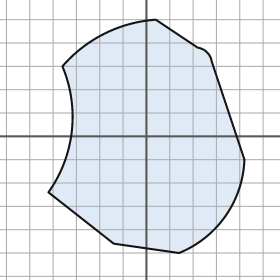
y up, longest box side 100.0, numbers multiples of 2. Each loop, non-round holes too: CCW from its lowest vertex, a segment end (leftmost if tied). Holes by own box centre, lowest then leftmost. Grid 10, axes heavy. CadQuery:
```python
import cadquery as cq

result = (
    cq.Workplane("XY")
    .moveTo(14.0, -50.0)
    .threePointArc((34.0, -34.0), (42.0, -10.0))
    .lineTo(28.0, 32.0)
    .threePointArc((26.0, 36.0), (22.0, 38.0))
    .lineTo(4.0, 50.0)
    .threePointArc((-18.0, 44.0), (-36.0, 30.0))
    .threePointArc((-32.0, 2.0), (-42.0, -24.0))
    .lineTo(-14.0, -46.0)
    .close()
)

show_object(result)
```